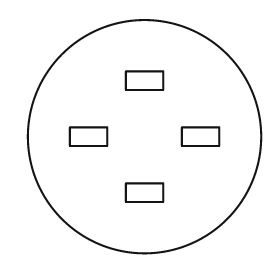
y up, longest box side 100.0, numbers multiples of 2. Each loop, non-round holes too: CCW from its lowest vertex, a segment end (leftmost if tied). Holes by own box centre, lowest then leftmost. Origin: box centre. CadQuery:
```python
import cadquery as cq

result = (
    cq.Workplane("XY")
    .moveTo(0.0, 0.0)
    .circle(50.0)
    .moveTo(-8.0, -28.0)
    .lineTo(8.0, -28.0)
    .lineTo(8.0, -20.0)
    .lineTo(-8.0, -20.0)
    .close()
    .moveTo(-32.0, -4.0)
    .lineTo(-16.0, -4.0)
    .lineTo(-16.0, 4.0)
    .lineTo(-32.0, 4.0)
    .close()
    .moveTo(16.0, -4.0)
    .lineTo(32.0, -4.0)
    .lineTo(32.0, 4.0)
    .lineTo(16.0, 4.0)
    .close()
    .moveTo(-8.0, 20.0)
    .lineTo(8.0, 20.0)
    .lineTo(8.0, 28.0)
    .lineTo(-8.0, 28.0)
    .close()
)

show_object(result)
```